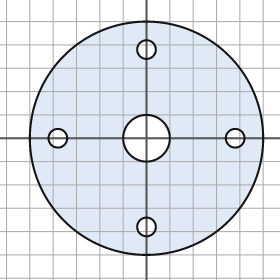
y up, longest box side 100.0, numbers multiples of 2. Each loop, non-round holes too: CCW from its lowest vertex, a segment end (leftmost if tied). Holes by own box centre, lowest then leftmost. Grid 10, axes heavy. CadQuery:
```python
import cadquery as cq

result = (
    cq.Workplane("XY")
    .moveTo(0.0, 0.0)
    .circle(50.0)
    .moveTo(0.0, -38.0)
    .circle(4.0)
    .moveTo(-38.0, 0.0)
    .circle(4.0)
    .moveTo(0.0, 0.0)
    .circle(10.0)
    .moveTo(38.0, 0.0)
    .circle(4.0)
    .moveTo(0.0, 38.0)
    .circle(4.0)
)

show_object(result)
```